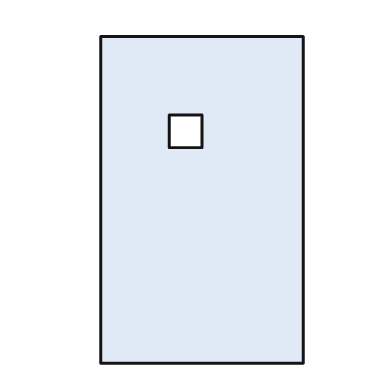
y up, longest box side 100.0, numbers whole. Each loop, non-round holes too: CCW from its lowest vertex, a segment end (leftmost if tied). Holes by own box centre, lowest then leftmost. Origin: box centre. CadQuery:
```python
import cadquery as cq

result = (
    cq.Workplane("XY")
    .moveTo(-31.0, -50.0)
    .lineTo(31.0, -50.0)
    .lineTo(31.0, 50.0)
    .lineTo(-31.0, 50.0)
    .close()
    .moveTo(-10.0, 16.0)
    .lineTo(0.0, 16.0)
    .lineTo(0.0, 26.0)
    .lineTo(-10.0, 26.0)
    .close()
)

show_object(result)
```